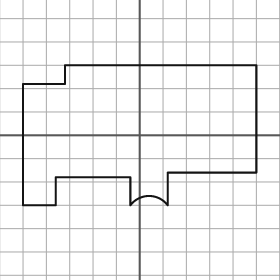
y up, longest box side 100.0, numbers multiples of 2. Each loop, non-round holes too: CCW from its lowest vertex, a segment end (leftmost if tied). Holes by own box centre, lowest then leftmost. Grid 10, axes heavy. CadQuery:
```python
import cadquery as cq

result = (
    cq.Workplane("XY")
    .moveTo(-50.0, -30.0)
    .lineTo(-36.0, -30.0)
    .lineTo(-36.0, -18.0)
    .lineTo(-4.0, -18.0)
    .lineTo(-4.0, -30.0)
    .threePointArc((4.0, -26.0), (12.0, -30.0))
    .lineTo(12.0, -16.0)
    .lineTo(50.0, -16.0)
    .lineTo(50.0, 30.0)
    .lineTo(-32.0, 30.0)
    .lineTo(-32.0, 22.0)
    .lineTo(-50.0, 22.0)
    .close()
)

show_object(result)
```